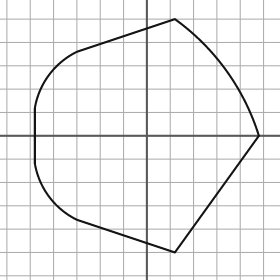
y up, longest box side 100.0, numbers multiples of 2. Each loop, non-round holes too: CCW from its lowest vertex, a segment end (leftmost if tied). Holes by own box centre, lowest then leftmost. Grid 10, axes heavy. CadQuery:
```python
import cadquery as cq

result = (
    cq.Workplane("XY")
    .moveTo(12.0, -50.0)
    .lineTo(48.0, 0.0)
    .threePointArc((34.0, 28.0), (12.0, 50.0))
    .lineTo(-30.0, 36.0)
    .threePointArc((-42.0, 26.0), (-48.0, 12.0))
    .lineTo(-48.0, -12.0)
    .threePointArc((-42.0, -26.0), (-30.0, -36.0))
    .close()
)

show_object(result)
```